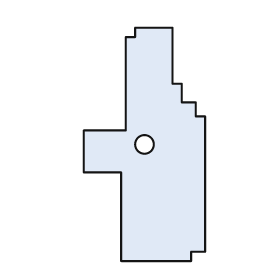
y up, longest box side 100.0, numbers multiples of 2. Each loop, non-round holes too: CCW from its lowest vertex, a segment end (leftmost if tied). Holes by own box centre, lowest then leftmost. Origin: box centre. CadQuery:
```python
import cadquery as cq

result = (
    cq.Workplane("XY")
    .moveTo(-10.0, -50.0)
    .lineTo(20.0, -50.0)
    .lineTo(20.0, -46.0)
    .lineTo(26.0, -46.0)
    .lineTo(26.0, 12.0)
    .lineTo(22.0, 12.0)
    .lineTo(22.0, 18.0)
    .lineTo(16.0, 18.0)
    .lineTo(16.0, 26.0)
    .lineTo(12.0, 26.0)
    .lineTo(12.0, 50.0)
    .lineTo(-4.0, 50.0)
    .lineTo(-4.0, 46.0)
    .lineTo(-8.0, 46.0)
    .lineTo(-8.0, 6.0)
    .lineTo(-26.0, 6.0)
    .lineTo(-26.0, -12.0)
    .lineTo(-10.0, -12.0)
    .close()
    .moveTo(0.0, 0.0)
    .circle(4.0)
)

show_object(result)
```